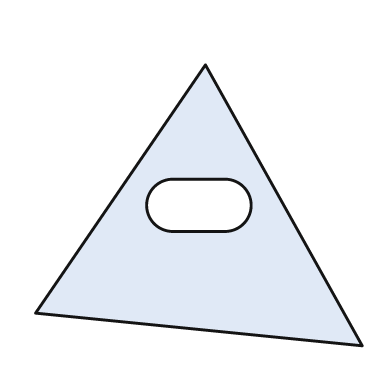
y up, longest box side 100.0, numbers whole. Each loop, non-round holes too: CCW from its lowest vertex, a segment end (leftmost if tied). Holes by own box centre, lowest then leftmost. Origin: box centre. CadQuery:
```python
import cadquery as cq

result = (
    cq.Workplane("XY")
    .moveTo(50.0, -43.0)
    .lineTo(2.0, 43.0)
    .lineTo(-50.0, -33.0)
    .close()
    .moveTo(-8.0, -8.0)
    .lineTo(8.0, -8.0)
    .threePointArc((16.0, 0.0), (8.0, 8.0))
    .lineTo(-8.0, 8.0)
    .threePointArc((-16.0, 0.0), (-8.0, -8.0))
    .close()
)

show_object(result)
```